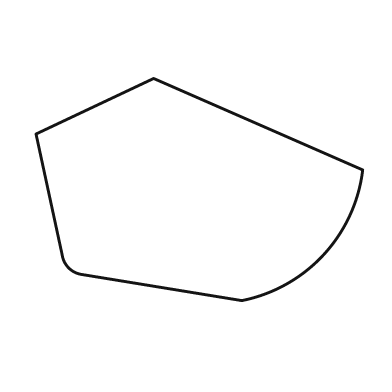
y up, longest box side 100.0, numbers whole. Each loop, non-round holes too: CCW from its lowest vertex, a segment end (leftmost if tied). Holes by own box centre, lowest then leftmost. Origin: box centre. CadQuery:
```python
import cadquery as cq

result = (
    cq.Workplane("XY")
    .moveTo(13.0, -34.0)
    .threePointArc((38.0, -20.0), (50.0, 6.0))
    .lineTo(-14.0, 34.0)
    .lineTo(-50.0, 17.0)
    .lineTo(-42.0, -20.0)
    .threePointArc((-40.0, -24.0), (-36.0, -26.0))
    .close()
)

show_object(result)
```